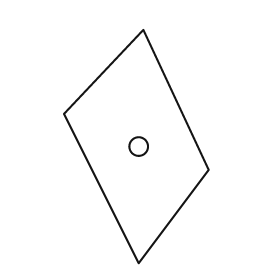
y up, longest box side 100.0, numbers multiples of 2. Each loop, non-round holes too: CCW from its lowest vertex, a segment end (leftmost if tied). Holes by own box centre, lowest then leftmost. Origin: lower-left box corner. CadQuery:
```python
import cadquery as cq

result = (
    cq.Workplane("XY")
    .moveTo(32.0, 0.0)
    .lineTo(62.0, 40.0)
    .lineTo(34.0, 100.0)
    .lineTo(0.0, 64.0)
    .close()
    .moveTo(32.0, 50.0)
    .circle(4.0)
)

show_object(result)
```